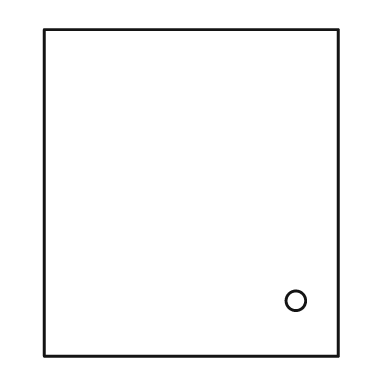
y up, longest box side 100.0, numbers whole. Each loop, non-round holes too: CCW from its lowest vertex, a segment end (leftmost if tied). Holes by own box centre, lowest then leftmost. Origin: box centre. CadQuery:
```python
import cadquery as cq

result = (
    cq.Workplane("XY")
    .moveTo(-45.0, -50.0)
    .lineTo(45.0, -50.0)
    .lineTo(45.0, 50.0)
    .lineTo(-45.0, 50.0)
    .close()
    .moveTo(32.0, -33.0)
    .circle(3.0)
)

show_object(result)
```